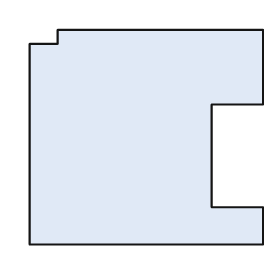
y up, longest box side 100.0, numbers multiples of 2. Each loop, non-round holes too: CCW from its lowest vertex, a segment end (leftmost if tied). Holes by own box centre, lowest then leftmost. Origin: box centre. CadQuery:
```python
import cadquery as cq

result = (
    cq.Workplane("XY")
    .moveTo(-50.0, -46.0)
    .lineTo(50.0, -46.0)
    .lineTo(50.0, -30.0)
    .lineTo(28.0, -30.0)
    .lineTo(28.0, 14.0)
    .lineTo(50.0, 14.0)
    .lineTo(50.0, 46.0)
    .lineTo(-38.0, 46.0)
    .lineTo(-38.0, 40.0)
    .lineTo(-50.0, 40.0)
    .close()
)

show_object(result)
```